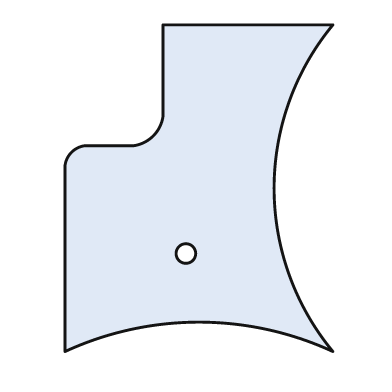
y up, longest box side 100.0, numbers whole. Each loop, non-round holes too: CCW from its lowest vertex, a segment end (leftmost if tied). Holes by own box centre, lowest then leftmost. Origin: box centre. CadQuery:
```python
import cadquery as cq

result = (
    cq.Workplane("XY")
    .moveTo(-41.0, -50.0)
    .threePointArc((0.0, -41.0), (41.0, -50.0))
    .threePointArc((23.0, 0.0), (41.0, 50.0))
    .lineTo(-11.0, 50.0)
    .lineTo(-11.0, 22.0)
    .threePointArc((-14.0, 16.0), (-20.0, 13.0))
    .lineTo(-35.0, 13.0)
    .threePointArc((-39.0, 11.0), (-41.0, 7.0))
    .close()
    .moveTo(-4.0, -20.0)
    .circle(3.0)
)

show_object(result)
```